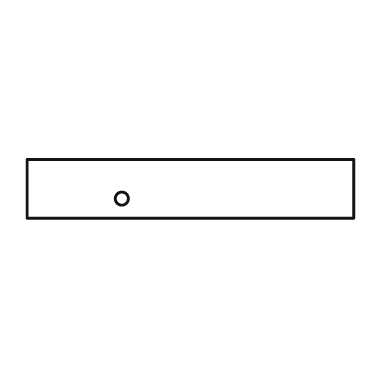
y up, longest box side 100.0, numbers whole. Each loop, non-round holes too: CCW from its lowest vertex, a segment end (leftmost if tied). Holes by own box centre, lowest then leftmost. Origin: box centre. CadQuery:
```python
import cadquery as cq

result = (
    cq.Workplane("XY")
    .moveTo(-50.0, -9.0)
    .lineTo(50.0, -9.0)
    .lineTo(50.0, 9.0)
    .lineTo(-50.0, 9.0)
    .close()
    .moveTo(-21.0, -3.0)
    .circle(2.0)
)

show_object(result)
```